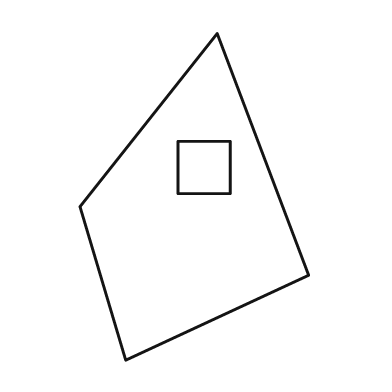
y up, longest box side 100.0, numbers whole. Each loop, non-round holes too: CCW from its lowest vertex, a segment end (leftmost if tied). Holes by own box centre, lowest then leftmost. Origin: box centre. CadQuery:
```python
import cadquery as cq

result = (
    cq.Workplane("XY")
    .moveTo(-21.0, -50.0)
    .lineTo(35.0, -24.0)
    .lineTo(7.0, 50.0)
    .lineTo(-35.0, -3.0)
    .close()
    .moveTo(-5.0, 1.0)
    .lineTo(11.0, 1.0)
    .lineTo(11.0, 17.0)
    .lineTo(-5.0, 17.0)
    .close()
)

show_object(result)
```